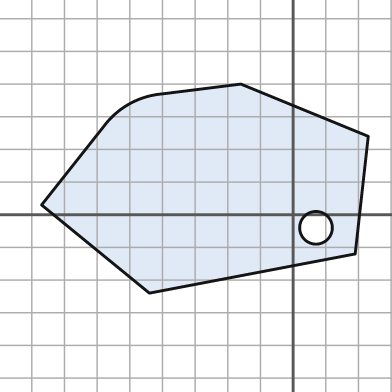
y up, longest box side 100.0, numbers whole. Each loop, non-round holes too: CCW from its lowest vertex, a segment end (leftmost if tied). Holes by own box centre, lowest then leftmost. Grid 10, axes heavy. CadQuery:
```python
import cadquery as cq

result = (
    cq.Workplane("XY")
    .moveTo(-44.0, -24.0)
    .lineTo(19.0, -12.0)
    .lineTo(23.0, 24.0)
    .lineTo(-16.0, 40.0)
    .lineTo(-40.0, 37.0)
    .threePointArc((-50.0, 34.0), (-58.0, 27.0))
    .lineTo(-77.0, 3.0)
    .close()
    .moveTo(7.0, -4.0)
    .circle(5.0)
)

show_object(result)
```